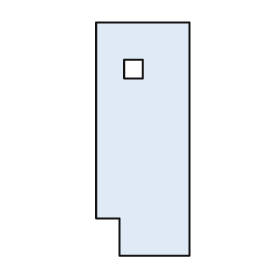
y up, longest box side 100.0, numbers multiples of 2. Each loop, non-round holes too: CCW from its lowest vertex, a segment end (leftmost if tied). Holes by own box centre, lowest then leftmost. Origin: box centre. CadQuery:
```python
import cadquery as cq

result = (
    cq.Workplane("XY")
    .moveTo(-10.0, -50.0)
    .lineTo(20.0, -50.0)
    .lineTo(20.0, 50.0)
    .lineTo(-20.0, 50.0)
    .lineTo(-20.0, -34.0)
    .lineTo(-10.0, -34.0)
    .close()
    .moveTo(-8.0, 26.0)
    .lineTo(0.0, 26.0)
    .lineTo(0.0, 34.0)
    .lineTo(-8.0, 34.0)
    .close()
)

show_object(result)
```